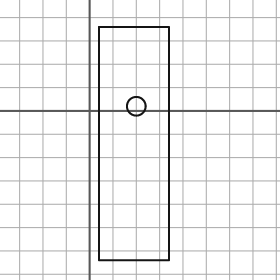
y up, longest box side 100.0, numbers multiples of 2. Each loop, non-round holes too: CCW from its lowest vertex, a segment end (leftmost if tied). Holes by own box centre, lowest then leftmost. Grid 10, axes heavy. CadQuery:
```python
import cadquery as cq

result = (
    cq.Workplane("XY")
    .moveTo(4.0, -64.0)
    .lineTo(34.0, -64.0)
    .lineTo(34.0, 36.0)
    .lineTo(4.0, 36.0)
    .close()
    .moveTo(20.0, 2.0)
    .circle(4.0)
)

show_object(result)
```